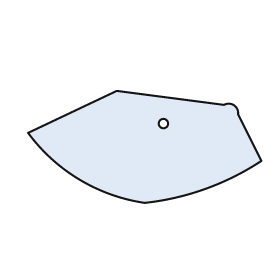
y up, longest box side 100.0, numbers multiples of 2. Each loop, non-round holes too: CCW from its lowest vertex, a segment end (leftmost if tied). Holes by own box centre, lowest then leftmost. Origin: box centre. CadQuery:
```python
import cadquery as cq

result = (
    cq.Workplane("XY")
    .moveTo(0.0, -24.0)
    .threePointArc((26.0, -18.0), (50.0, -6.0))
    .lineTo(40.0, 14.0)
    .threePointArc((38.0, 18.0), (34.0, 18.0))
    .lineTo(-12.0, 24.0)
    .lineTo(-50.0, 6.0)
    .threePointArc((-28.0, -14.0), (0.0, -24.0))
    .close()
    .moveTo(8.0, 10.0)
    .circle(2.0)
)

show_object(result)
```